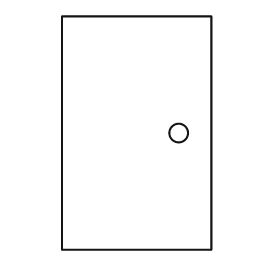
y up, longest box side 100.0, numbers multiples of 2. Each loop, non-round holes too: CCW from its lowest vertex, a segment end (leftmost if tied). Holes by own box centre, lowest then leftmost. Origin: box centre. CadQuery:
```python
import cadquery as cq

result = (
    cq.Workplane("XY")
    .moveTo(-32.0, -50.0)
    .lineTo(32.0, -50.0)
    .lineTo(32.0, 50.0)
    .lineTo(-32.0, 50.0)
    .close()
    .moveTo(18.0, 0.0)
    .circle(4.0)
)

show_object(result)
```